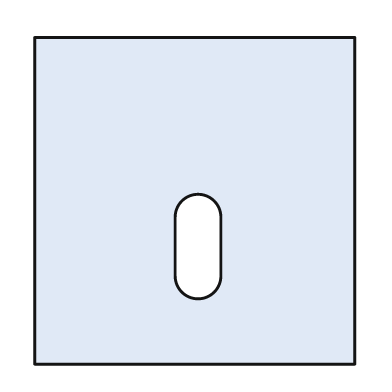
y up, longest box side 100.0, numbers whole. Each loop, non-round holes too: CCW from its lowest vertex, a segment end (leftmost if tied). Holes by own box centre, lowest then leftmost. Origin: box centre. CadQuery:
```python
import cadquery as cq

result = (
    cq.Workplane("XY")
    .moveTo(-49.0, -50.0)
    .lineTo(49.0, -50.0)
    .lineTo(49.0, 50.0)
    .lineTo(-49.0, 50.0)
    .close()
    .moveTo(-6.0, -23.0)
    .threePointArc((1.0, -30.0), (8.0, -23.0))
    .lineTo(8.0, -5.0)
    .threePointArc((1.0, 2.0), (-6.0, -5.0))
    .close()
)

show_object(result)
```